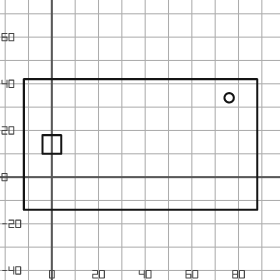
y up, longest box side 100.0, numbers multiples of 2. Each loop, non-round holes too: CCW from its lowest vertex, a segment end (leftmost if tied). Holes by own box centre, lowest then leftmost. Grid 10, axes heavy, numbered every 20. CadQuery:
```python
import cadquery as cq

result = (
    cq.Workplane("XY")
    .moveTo(-12.0, -14.0)
    .lineTo(88.0, -14.0)
    .lineTo(88.0, 42.0)
    .lineTo(-12.0, 42.0)
    .close()
    .moveTo(-4.0, 10.0)
    .lineTo(4.0, 10.0)
    .lineTo(4.0, 18.0)
    .lineTo(-4.0, 18.0)
    .close()
    .moveTo(76.0, 34.0)
    .circle(2.0)
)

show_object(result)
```